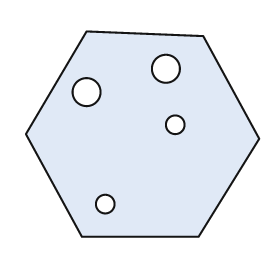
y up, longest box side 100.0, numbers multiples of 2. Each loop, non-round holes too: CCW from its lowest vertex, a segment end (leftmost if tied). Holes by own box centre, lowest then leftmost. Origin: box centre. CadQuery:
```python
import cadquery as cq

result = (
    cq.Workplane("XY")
    .moveTo(-26.0, -44.0)
    .lineTo(24.0, -44.0)
    .lineTo(50.0, -2.0)
    .lineTo(26.0, 42.0)
    .lineTo(-24.0, 44.0)
    .lineTo(-50.0, 0.0)
    .close()
    .moveTo(-16.0, -30.0)
    .circle(4.0)
    .moveTo(14.0, 4.0)
    .circle(4.0)
    .moveTo(-24.0, 18.0)
    .circle(6.0)
    .moveTo(10.0, 28.0)
    .circle(6.0)
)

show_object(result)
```